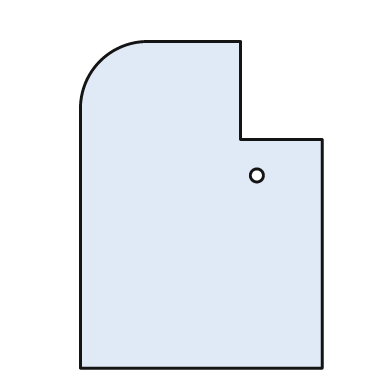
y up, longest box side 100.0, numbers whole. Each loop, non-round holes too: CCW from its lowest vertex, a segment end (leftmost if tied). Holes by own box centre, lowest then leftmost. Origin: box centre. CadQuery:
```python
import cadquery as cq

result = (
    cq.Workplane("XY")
    .moveTo(-37.0, -50.0)
    .lineTo(37.0, -50.0)
    .lineTo(37.0, 20.0)
    .lineTo(12.0, 20.0)
    .lineTo(12.0, 50.0)
    .lineTo(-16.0, 50.0)
    .threePointArc((-31.0, 44.0), (-37.0, 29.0))
    .close()
    .moveTo(17.0, 9.0)
    .circle(2.0)
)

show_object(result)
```